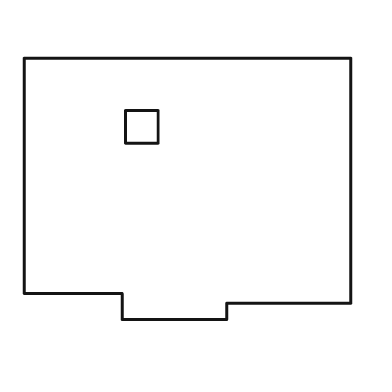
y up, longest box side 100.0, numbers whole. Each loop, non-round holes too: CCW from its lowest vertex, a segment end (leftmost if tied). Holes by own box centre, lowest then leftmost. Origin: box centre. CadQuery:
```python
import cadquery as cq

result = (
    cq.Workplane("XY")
    .moveTo(-20.0, -40.0)
    .lineTo(12.0, -40.0)
    .lineTo(12.0, -35.0)
    .lineTo(50.0, -35.0)
    .lineTo(50.0, 40.0)
    .lineTo(-50.0, 40.0)
    .lineTo(-50.0, -32.0)
    .lineTo(-20.0, -32.0)
    .close()
    .moveTo(-19.0, 14.0)
    .lineTo(-9.0, 14.0)
    .lineTo(-9.0, 24.0)
    .lineTo(-19.0, 24.0)
    .close()
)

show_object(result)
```